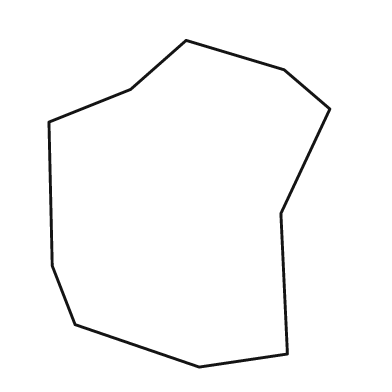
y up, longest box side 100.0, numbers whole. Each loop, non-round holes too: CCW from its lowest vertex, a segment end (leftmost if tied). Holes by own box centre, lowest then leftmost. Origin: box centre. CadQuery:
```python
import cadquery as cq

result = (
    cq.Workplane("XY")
    .moveTo(3.0, -50.0)
    .lineTo(30.0, -46.0)
    .lineTo(28.0, -3.0)
    .lineTo(43.0, 29.0)
    .lineTo(29.0, 41.0)
    .lineTo(-1.0, 50.0)
    .lineTo(-18.0, 35.0)
    .lineTo(-43.0, 25.0)
    .lineTo(-42.0, -19.0)
    .lineTo(-35.0, -37.0)
    .close()
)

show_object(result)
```